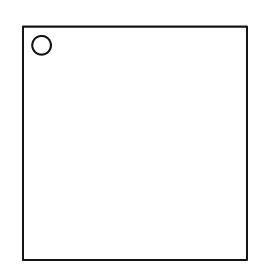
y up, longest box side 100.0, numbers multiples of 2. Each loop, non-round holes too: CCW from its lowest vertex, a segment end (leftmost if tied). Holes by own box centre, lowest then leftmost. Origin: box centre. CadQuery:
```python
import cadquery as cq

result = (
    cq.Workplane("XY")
    .moveTo(-48.0, -50.0)
    .lineTo(48.0, -50.0)
    .lineTo(48.0, 50.0)
    .lineTo(-48.0, 50.0)
    .close()
    .moveTo(-40.0, 42.0)
    .circle(4.0)
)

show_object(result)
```